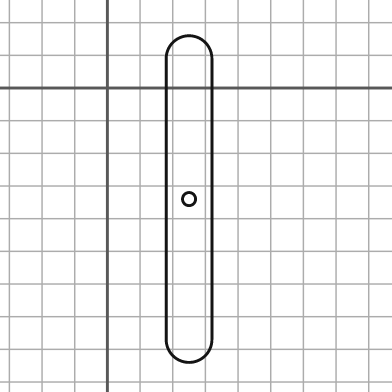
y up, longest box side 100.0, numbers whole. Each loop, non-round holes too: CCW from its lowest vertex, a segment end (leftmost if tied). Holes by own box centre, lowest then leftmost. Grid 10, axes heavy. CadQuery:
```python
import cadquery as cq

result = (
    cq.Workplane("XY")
    .moveTo(18.0, -77.0)
    .threePointArc((25.0, -84.0), (32.0, -77.0))
    .lineTo(32.0, 9.0)
    .threePointArc((25.0, 16.0), (18.0, 9.0))
    .close()
    .moveTo(25.0, -34.0)
    .circle(2.0)
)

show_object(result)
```